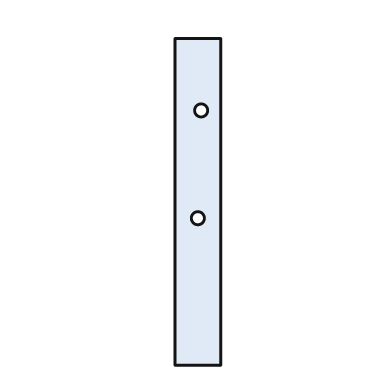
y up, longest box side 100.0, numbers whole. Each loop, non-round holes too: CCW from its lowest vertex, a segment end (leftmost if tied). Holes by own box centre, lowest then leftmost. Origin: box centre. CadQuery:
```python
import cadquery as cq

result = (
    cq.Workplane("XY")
    .moveTo(-7.0, -50.0)
    .lineTo(7.0, -50.0)
    .lineTo(7.0, 50.0)
    .lineTo(-7.0, 50.0)
    .close()
    .moveTo(0.0, -5.0)
    .circle(2.0)
    .moveTo(1.0, 28.0)
    .circle(2.0)
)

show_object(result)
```